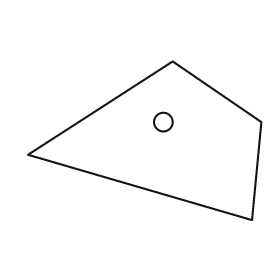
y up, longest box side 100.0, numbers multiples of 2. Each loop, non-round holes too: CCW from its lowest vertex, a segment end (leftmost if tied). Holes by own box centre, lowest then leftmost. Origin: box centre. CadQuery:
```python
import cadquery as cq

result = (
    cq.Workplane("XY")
    .moveTo(46.0, -34.0)
    .lineTo(50.0, 8.0)
    .lineTo(12.0, 34.0)
    .lineTo(-50.0, -6.0)
    .close()
    .moveTo(8.0, 8.0)
    .circle(4.0)
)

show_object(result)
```